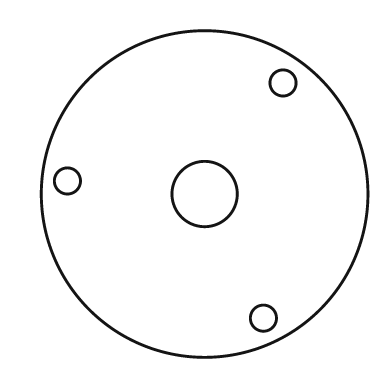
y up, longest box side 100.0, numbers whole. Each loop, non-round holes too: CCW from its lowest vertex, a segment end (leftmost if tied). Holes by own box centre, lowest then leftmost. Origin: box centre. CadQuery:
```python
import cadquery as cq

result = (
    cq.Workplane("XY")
    .moveTo(0.0, 0.0)
    .circle(50.0)
    .moveTo(18.0, -38.0)
    .circle(4.0)
    .moveTo(0.0, 0.0)
    .circle(10.0)
    .moveTo(-42.0, 4.0)
    .circle(4.0)
    .moveTo(24.0, 34.0)
    .circle(4.0)
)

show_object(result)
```